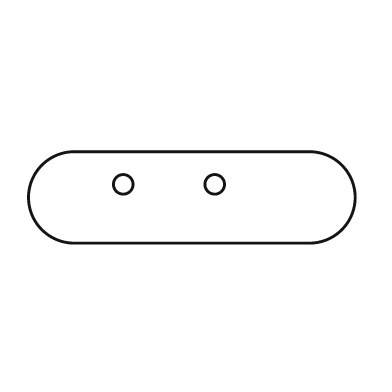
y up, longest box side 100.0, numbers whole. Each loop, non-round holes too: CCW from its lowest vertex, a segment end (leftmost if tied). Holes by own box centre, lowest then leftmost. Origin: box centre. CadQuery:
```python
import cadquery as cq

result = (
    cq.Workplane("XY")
    .moveTo(-36.0, -14.0)
    .lineTo(36.0, -14.0)
    .threePointArc((50.0, 0.0), (36.0, 14.0))
    .lineTo(-36.0, 14.0)
    .threePointArc((-50.0, 0.0), (-36.0, -14.0))
    .close()
    .moveTo(-21.0, 4.0)
    .circle(3.0)
    .moveTo(7.0, 4.0)
    .circle(3.0)
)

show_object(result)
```